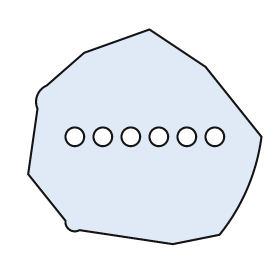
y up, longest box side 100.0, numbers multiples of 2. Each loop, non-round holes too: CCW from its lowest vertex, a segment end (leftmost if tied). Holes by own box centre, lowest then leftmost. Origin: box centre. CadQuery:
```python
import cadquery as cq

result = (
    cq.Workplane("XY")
    .moveTo(12.0, -46.0)
    .lineTo(32.0, -42.0)
    .threePointArc((44.0, -22.0), (50.0, 0.0))
    .lineTo(26.0, 30.0)
    .lineTo(2.0, 46.0)
    .lineTo(-26.0, 36.0)
    .lineTo(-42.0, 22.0)
    .threePointArc((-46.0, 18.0), (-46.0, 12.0))
    .lineTo(-50.0, -16.0)
    .lineTo(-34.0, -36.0)
    .threePointArc((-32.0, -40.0), (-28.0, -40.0))
    .close()
    .moveTo(-30.0, 0.0)
    .circle(4.0)
    .moveTo(-18.0, 0.0)
    .circle(4.0)
    .moveTo(-6.0, 0.0)
    .circle(4.0)
    .moveTo(6.0, 0.0)
    .circle(4.0)
    .moveTo(18.0, 0.0)
    .circle(4.0)
    .moveTo(30.0, 0.0)
    .circle(4.0)
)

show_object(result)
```